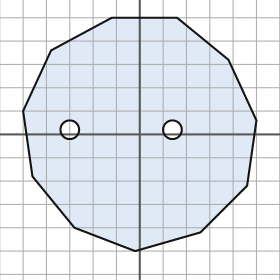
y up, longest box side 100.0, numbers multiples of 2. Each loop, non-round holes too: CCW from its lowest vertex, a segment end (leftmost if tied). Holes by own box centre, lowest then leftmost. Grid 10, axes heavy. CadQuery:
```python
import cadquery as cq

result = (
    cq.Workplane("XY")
    .moveTo(-2.0, -50.0)
    .lineTo(26.0, -42.0)
    .lineTo(46.0, -22.0)
    .lineTo(50.0, 6.0)
    .lineTo(38.0, 32.0)
    .lineTo(16.0, 50.0)
    .lineTo(-12.0, 50.0)
    .lineTo(-38.0, 36.0)
    .lineTo(-50.0, 10.0)
    .lineTo(-46.0, -18.0)
    .lineTo(-28.0, -40.0)
    .close()
    .moveTo(-30.0, 2.0)
    .circle(4.0)
    .moveTo(14.0, 2.0)
    .circle(4.0)
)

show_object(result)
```